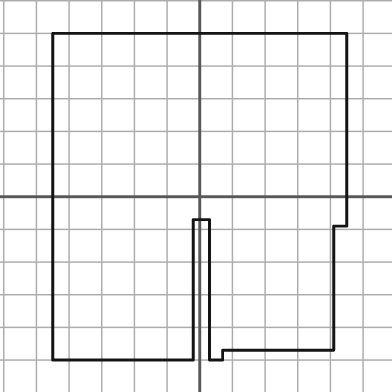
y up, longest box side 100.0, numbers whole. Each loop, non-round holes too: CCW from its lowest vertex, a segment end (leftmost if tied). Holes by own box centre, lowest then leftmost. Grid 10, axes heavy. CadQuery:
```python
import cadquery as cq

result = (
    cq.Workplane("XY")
    .moveTo(-45.0, -50.0)
    .lineTo(-2.0, -50.0)
    .lineTo(-2.0, -7.0)
    .lineTo(3.0, -7.0)
    .lineTo(3.0, -50.0)
    .lineTo(7.0, -50.0)
    .lineTo(7.0, -47.0)
    .lineTo(41.0, -47.0)
    .lineTo(41.0, -9.0)
    .lineTo(45.0, -9.0)
    .lineTo(45.0, 50.0)
    .lineTo(-45.0, 50.0)
    .close()
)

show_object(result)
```